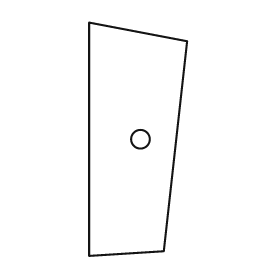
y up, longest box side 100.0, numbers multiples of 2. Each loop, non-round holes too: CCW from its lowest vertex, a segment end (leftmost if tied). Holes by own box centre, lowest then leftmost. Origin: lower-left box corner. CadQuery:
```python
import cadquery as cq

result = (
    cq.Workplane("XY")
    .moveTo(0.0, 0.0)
    .lineTo(32.0, 2.0)
    .lineTo(42.0, 92.0)
    .lineTo(0.0, 100.0)
    .close()
    .moveTo(22.0, 50.0)
    .circle(4.0)
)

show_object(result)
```